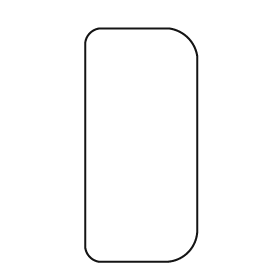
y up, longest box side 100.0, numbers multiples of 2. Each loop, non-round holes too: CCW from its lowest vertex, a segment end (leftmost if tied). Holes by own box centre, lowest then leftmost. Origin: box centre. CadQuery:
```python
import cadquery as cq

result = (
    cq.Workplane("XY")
    .moveTo(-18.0, -50.0)
    .lineTo(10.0, -50.0)
    .threePointArc((20.0, -46.0), (24.0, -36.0))
    .lineTo(24.0, 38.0)
    .threePointArc((20.0, 46.0), (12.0, 50.0))
    .lineTo(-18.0, 50.0)
    .threePointArc((-22.0, 48.0), (-24.0, 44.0))
    .lineTo(-24.0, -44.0)
    .threePointArc((-22.0, -48.0), (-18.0, -50.0))
    .close()
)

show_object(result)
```